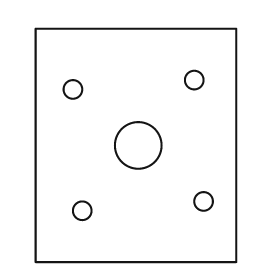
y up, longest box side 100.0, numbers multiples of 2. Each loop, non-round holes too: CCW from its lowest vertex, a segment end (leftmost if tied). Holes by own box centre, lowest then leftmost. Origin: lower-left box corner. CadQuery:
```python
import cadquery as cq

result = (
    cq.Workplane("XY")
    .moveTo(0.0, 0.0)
    .lineTo(86.0, 0.0)
    .lineTo(86.0, 100.0)
    .lineTo(0.0, 100.0)
    .close()
    .moveTo(20.0, 22.0)
    .circle(4.0)
    .moveTo(72.0, 26.0)
    .circle(4.0)
    .moveTo(44.0, 50.0)
    .circle(10.0)
    .moveTo(16.0, 74.0)
    .circle(4.0)
    .moveTo(68.0, 78.0)
    .circle(4.0)
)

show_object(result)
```